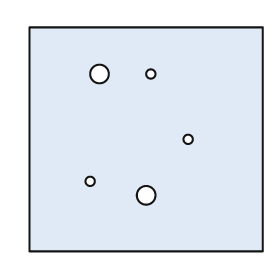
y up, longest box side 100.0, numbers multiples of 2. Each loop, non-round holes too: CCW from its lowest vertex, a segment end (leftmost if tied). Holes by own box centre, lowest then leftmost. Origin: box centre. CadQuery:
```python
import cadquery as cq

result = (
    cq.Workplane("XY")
    .moveTo(-50.0, -48.0)
    .lineTo(50.0, -48.0)
    .lineTo(50.0, 48.0)
    .lineTo(-50.0, 48.0)
    .close()
    .moveTo(0.0, -24.0)
    .circle(4.0)
    .moveTo(-24.0, -18.0)
    .circle(2.0)
    .moveTo(18.0, 0.0)
    .circle(2.0)
    .moveTo(-20.0, 28.0)
    .circle(4.0)
    .moveTo(2.0, 28.0)
    .circle(2.0)
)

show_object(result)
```